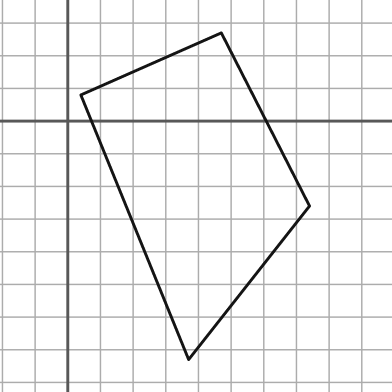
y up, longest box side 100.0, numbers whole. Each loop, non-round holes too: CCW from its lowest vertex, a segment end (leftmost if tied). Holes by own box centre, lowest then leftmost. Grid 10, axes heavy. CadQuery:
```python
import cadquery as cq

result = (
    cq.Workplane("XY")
    .moveTo(37.0, -73.0)
    .lineTo(74.0, -26.0)
    .lineTo(47.0, 27.0)
    .lineTo(4.0, 8.0)
    .close()
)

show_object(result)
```